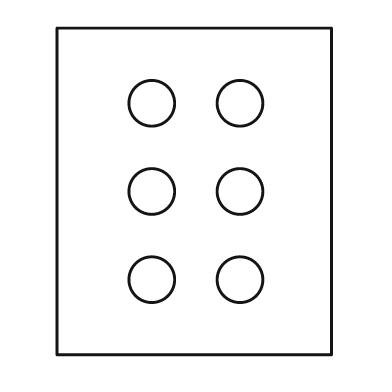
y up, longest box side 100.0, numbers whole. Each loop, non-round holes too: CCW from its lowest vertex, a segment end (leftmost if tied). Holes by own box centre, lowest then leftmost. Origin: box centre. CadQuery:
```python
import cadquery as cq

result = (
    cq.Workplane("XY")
    .moveTo(-42.0, -50.0)
    .lineTo(42.0, -50.0)
    .lineTo(42.0, 50.0)
    .lineTo(-42.0, 50.0)
    .close()
    .moveTo(-13.0, -27.0)
    .circle(7.0)
    .moveTo(14.0, -27.0)
    .circle(7.0)
    .moveTo(-13.0, 0.0)
    .circle(7.0)
    .moveTo(14.0, 0.0)
    .circle(7.0)
    .moveTo(-13.0, 27.0)
    .circle(7.0)
    .moveTo(14.0, 27.0)
    .circle(7.0)
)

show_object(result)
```